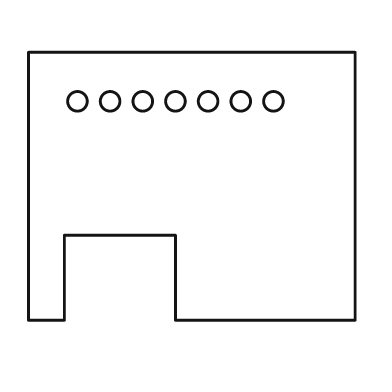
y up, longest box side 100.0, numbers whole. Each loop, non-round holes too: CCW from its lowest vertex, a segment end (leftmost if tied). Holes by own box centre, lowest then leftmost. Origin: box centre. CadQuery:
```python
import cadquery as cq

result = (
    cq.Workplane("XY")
    .moveTo(-50.0, -41.0)
    .lineTo(-39.0, -41.0)
    .lineTo(-39.0, -15.0)
    .lineTo(-5.0, -15.0)
    .lineTo(-5.0, -41.0)
    .lineTo(50.0, -41.0)
    .lineTo(50.0, 41.0)
    .lineTo(-50.0, 41.0)
    .close()
    .moveTo(-35.0, 26.0)
    .circle(3.0)
    .moveTo(-25.0, 26.0)
    .circle(3.0)
    .moveTo(-15.0, 26.0)
    .circle(3.0)
    .moveTo(-5.0, 26.0)
    .circle(3.0)
    .moveTo(5.0, 26.0)
    .circle(3.0)
    .moveTo(15.0, 26.0)
    .circle(3.0)
    .moveTo(25.0, 26.0)
    .circle(3.0)
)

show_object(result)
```